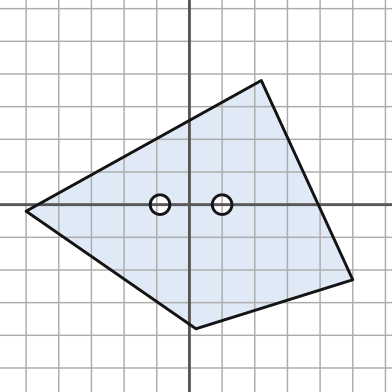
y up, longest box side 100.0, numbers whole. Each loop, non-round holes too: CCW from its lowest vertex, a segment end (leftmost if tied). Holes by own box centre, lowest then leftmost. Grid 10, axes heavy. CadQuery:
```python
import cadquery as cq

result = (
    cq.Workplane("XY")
    .moveTo(2.0, -38.0)
    .lineTo(50.0, -23.0)
    .lineTo(22.0, 38.0)
    .lineTo(-50.0, -2.0)
    .close()
    .moveTo(-9.0, 0.0)
    .circle(3.0)
    .moveTo(10.0, 0.0)
    .circle(3.0)
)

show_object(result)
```